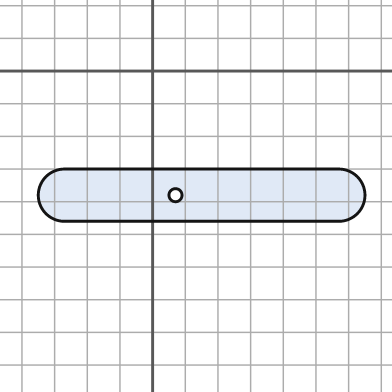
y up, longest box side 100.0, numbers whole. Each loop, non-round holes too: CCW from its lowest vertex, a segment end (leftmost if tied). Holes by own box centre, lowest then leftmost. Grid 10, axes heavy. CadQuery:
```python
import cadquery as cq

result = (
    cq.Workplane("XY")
    .moveTo(-27.0, -46.0)
    .lineTo(57.0, -46.0)
    .threePointArc((65.0, -38.0), (57.0, -30.0))
    .lineTo(-27.0, -30.0)
    .threePointArc((-35.0, -38.0), (-27.0, -46.0))
    .close()
    .moveTo(7.0, -38.0)
    .circle(2.0)
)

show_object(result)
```